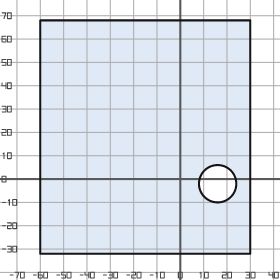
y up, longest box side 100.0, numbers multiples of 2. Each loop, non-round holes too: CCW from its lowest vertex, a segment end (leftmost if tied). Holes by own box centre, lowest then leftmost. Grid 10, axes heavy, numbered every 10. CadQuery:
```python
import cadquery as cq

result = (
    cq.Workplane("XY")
    .moveTo(-60.0, -32.0)
    .lineTo(30.0, -32.0)
    .lineTo(30.0, 68.0)
    .lineTo(-60.0, 68.0)
    .close()
    .moveTo(16.0, -2.0)
    .circle(8.0)
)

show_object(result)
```